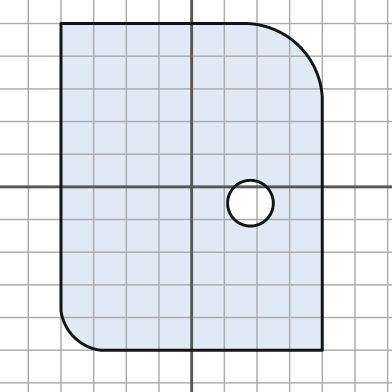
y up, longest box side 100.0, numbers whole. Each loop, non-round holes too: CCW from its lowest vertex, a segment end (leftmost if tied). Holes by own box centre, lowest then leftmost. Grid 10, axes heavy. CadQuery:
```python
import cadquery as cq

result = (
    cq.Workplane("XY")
    .moveTo(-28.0, -50.0)
    .lineTo(40.0, -50.0)
    .lineTo(40.0, 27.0)
    .threePointArc((33.0, 43.0), (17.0, 50.0))
    .lineTo(-40.0, 50.0)
    .lineTo(-40.0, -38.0)
    .threePointArc((-36.0, -46.0), (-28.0, -50.0))
    .close()
    .moveTo(18.0, -5.0)
    .circle(7.0)
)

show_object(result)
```